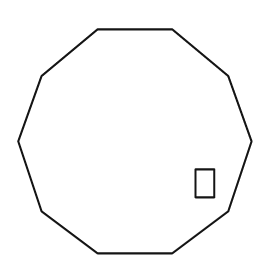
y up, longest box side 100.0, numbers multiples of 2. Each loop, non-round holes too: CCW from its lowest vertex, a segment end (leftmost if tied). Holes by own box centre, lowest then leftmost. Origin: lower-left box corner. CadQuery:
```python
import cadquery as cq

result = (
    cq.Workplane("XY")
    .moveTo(34.0, 0.0)
    .lineTo(66.0, 0.0)
    .lineTo(90.0, 18.0)
    .lineTo(100.0, 48.0)
    .lineTo(90.0, 76.0)
    .lineTo(66.0, 96.0)
    .lineTo(34.0, 96.0)
    .lineTo(10.0, 76.0)
    .lineTo(0.0, 48.0)
    .lineTo(10.0, 18.0)
    .close()
    .moveTo(76.0, 24.0)
    .lineTo(84.0, 24.0)
    .lineTo(84.0, 36.0)
    .lineTo(76.0, 36.0)
    .close()
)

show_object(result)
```